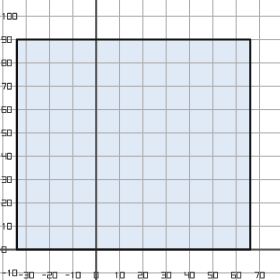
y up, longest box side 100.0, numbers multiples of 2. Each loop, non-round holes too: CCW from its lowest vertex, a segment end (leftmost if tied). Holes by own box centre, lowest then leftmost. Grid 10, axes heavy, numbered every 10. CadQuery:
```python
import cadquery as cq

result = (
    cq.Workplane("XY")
    .moveTo(-34.0, 0.0)
    .lineTo(66.0, 0.0)
    .lineTo(66.0, 90.0)
    .lineTo(-34.0, 90.0)
    .close()
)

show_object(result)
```